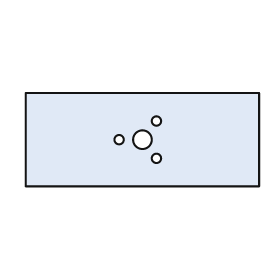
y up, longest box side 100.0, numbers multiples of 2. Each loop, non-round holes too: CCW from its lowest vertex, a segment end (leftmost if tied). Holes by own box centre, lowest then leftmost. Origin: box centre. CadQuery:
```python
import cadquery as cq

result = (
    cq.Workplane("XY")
    .moveTo(-50.0, -20.0)
    .lineTo(50.0, -20.0)
    .lineTo(50.0, 20.0)
    .lineTo(-50.0, 20.0)
    .close()
    .moveTo(6.0, -8.0)
    .circle(2.0)
    .moveTo(-10.0, 0.0)
    .circle(2.0)
    .moveTo(0.0, 0.0)
    .circle(4.0)
    .moveTo(6.0, 8.0)
    .circle(2.0)
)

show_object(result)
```